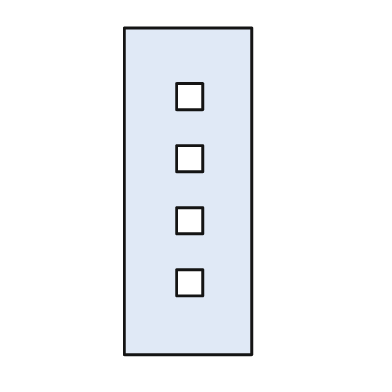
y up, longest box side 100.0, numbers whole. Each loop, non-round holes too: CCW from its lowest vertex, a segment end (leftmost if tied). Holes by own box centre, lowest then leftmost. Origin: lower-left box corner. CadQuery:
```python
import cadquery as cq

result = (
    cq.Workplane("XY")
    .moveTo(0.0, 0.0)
    .lineTo(39.0, 0.0)
    .lineTo(39.0, 100.0)
    .lineTo(0.0, 100.0)
    .close()
    .moveTo(16.0, 18.0)
    .lineTo(24.0, 18.0)
    .lineTo(24.0, 26.0)
    .lineTo(16.0, 26.0)
    .close()
    .moveTo(16.0, 37.0)
    .lineTo(24.0, 37.0)
    .lineTo(24.0, 45.0)
    .lineTo(16.0, 45.0)
    .close()
    .moveTo(16.0, 56.0)
    .lineTo(24.0, 56.0)
    .lineTo(24.0, 64.0)
    .lineTo(16.0, 64.0)
    .close()
    .moveTo(16.0, 75.0)
    .lineTo(24.0, 75.0)
    .lineTo(24.0, 83.0)
    .lineTo(16.0, 83.0)
    .close()
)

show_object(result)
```